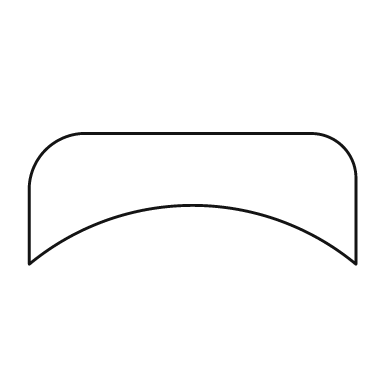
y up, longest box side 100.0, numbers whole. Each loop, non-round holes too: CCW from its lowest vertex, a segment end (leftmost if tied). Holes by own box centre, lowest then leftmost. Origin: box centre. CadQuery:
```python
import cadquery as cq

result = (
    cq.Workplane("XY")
    .moveTo(-50.0, -20.0)
    .threePointArc((0.0, -2.0), (50.0, -20.0))
    .lineTo(50.0, 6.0)
    .threePointArc((46.0, 16.0), (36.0, 20.0))
    .lineTo(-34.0, 20.0)
    .threePointArc((-45.0, 15.0), (-50.0, 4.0))
    .close()
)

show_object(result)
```